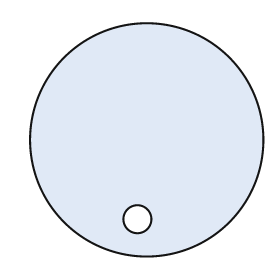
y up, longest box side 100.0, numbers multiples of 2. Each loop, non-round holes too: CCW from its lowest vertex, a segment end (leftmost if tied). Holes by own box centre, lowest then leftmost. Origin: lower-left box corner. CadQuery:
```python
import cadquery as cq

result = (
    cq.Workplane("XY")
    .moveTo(50.0, 50.0)
    .circle(50.0)
    .moveTo(46.0, 16.0)
    .circle(6.0)
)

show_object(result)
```